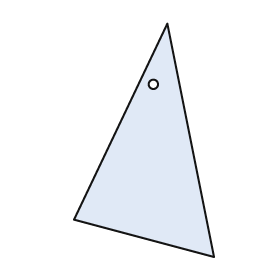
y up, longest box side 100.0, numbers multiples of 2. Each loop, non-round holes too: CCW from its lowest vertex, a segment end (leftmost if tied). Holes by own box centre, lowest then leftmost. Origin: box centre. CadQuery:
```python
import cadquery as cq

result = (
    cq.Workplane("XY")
    .moveTo(30.0, -50.0)
    .lineTo(10.0, 50.0)
    .lineTo(-30.0, -34.0)
    .close()
    .moveTo(4.0, 24.0)
    .circle(2.0)
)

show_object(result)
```